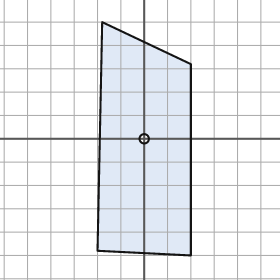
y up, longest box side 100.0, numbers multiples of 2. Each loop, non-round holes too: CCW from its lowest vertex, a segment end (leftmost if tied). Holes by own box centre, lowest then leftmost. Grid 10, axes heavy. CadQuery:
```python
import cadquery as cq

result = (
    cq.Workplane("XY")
    .moveTo(20.0, -50.0)
    .lineTo(20.0, 32.0)
    .lineTo(-18.0, 50.0)
    .lineTo(-20.0, -48.0)
    .close()
    .moveTo(0.0, 0.0)
    .circle(2.0)
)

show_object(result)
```